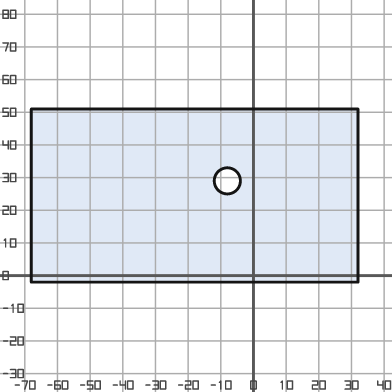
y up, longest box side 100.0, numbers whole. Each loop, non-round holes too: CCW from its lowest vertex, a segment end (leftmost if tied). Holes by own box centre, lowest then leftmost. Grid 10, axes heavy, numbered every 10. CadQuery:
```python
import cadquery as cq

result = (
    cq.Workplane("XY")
    .moveTo(-68.0, -2.0)
    .lineTo(32.0, -2.0)
    .lineTo(32.0, 51.0)
    .lineTo(-68.0, 51.0)
    .close()
    .moveTo(-8.0, 29.0)
    .circle(4.0)
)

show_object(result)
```